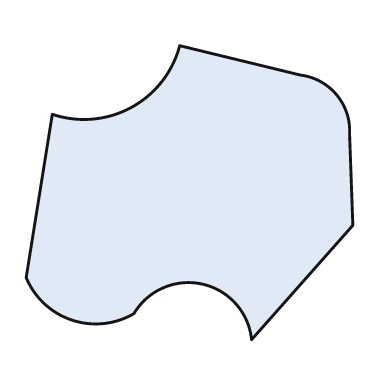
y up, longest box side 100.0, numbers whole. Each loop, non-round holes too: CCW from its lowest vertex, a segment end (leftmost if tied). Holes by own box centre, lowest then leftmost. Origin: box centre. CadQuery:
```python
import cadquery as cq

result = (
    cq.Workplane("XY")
    .moveTo(19.0, -45.0)
    .lineTo(50.0, -10.0)
    .lineTo(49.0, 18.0)
    .threePointArc((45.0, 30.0), (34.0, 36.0))
    .lineTo(-3.0, 45.0)
    .threePointArc((-18.0, 26.0), (-42.0, 24.0))
    .lineTo(-50.0, -26.0)
    .threePointArc((-36.0, -39.0), (-17.0, -37.0))
    .threePointArc((4.0, -28.0), (19.0, -45.0))
    .close()
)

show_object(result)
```